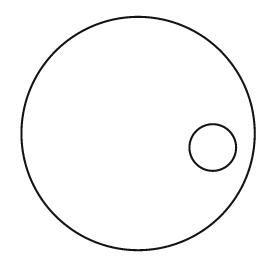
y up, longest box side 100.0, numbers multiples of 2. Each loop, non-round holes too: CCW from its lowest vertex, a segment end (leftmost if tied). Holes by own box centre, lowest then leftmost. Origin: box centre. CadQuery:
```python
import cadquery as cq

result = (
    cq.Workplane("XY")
    .moveTo(0.0, 0.0)
    .circle(50.0)
    .moveTo(32.0, -6.0)
    .circle(10.0)
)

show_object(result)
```